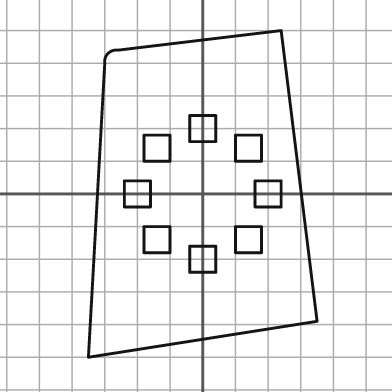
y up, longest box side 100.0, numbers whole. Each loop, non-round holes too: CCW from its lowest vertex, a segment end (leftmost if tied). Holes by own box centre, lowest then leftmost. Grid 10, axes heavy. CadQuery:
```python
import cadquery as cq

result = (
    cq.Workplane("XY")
    .moveTo(-35.0, -50.0)
    .lineTo(35.0, -39.0)
    .lineTo(24.0, 50.0)
    .lineTo(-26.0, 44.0)
    .threePointArc((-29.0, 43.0), (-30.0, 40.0))
    .close()
    .moveTo(-4.0, -24.0)
    .lineTo(4.0, -24.0)
    .lineTo(4.0, -16.0)
    .lineTo(-4.0, -16.0)
    .close()
    .moveTo(-18.0, -18.0)
    .lineTo(-10.0, -18.0)
    .lineTo(-10.0, -10.0)
    .lineTo(-18.0, -10.0)
    .close()
    .moveTo(10.0, -18.0)
    .lineTo(18.0, -18.0)
    .lineTo(18.0, -10.0)
    .lineTo(10.0, -10.0)
    .close()
    .moveTo(-24.0, -4.0)
    .lineTo(-16.0, -4.0)
    .lineTo(-16.0, 4.0)
    .lineTo(-24.0, 4.0)
    .close()
    .moveTo(16.0, -4.0)
    .lineTo(24.0, -4.0)
    .lineTo(24.0, 4.0)
    .lineTo(16.0, 4.0)
    .close()
    .moveTo(-18.0, 10.0)
    .lineTo(-10.0, 10.0)
    .lineTo(-10.0, 18.0)
    .lineTo(-18.0, 18.0)
    .close()
    .moveTo(10.0, 10.0)
    .lineTo(18.0, 10.0)
    .lineTo(18.0, 18.0)
    .lineTo(10.0, 18.0)
    .close()
    .moveTo(-4.0, 16.0)
    .lineTo(4.0, 16.0)
    .lineTo(4.0, 24.0)
    .lineTo(-4.0, 24.0)
    .close()
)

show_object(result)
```